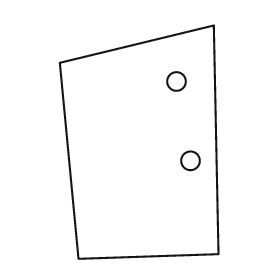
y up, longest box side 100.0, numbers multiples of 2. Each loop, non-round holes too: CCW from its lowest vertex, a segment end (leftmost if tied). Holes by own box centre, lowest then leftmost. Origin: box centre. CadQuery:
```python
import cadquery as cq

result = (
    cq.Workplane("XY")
    .moveTo(-26.0, -50.0)
    .lineTo(34.0, -48.0)
    .lineTo(32.0, 50.0)
    .lineTo(-34.0, 34.0)
    .close()
    .moveTo(22.0, -8.0)
    .circle(4.0)
    .moveTo(16.0, 26.0)
    .circle(4.0)
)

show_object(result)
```